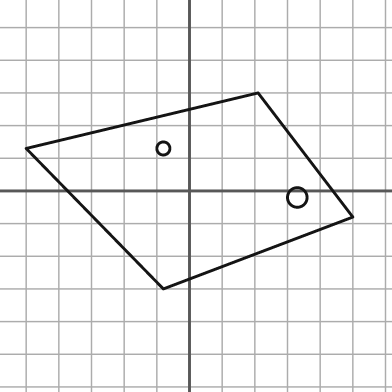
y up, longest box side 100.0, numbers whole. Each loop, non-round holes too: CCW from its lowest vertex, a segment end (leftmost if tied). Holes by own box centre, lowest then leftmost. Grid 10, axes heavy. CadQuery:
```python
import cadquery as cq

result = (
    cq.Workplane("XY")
    .moveTo(-8.0, -30.0)
    .lineTo(50.0, -8.0)
    .lineTo(21.0, 30.0)
    .lineTo(-50.0, 13.0)
    .close()
    .moveTo(33.0, -2.0)
    .circle(3.0)
    .moveTo(-8.0, 13.0)
    .circle(2.0)
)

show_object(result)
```